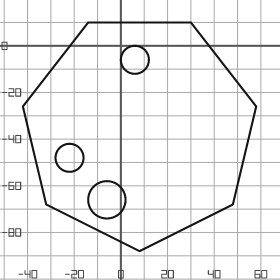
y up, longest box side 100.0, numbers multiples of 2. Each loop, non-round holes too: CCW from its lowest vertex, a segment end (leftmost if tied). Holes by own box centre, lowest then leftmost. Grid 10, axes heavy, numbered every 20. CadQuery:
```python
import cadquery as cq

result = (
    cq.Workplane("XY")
    .moveTo(8.0, -88.0)
    .lineTo(48.0, -68.0)
    .lineTo(58.0, -26.0)
    .lineTo(30.0, 10.0)
    .lineTo(-14.0, 10.0)
    .lineTo(-42.0, -26.0)
    .lineTo(-32.0, -68.0)
    .close()
    .moveTo(-6.0, -66.0)
    .circle(8.0)
    .moveTo(-22.0, -48.0)
    .circle(6.0)
    .moveTo(6.0, -6.0)
    .circle(6.0)
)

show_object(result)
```